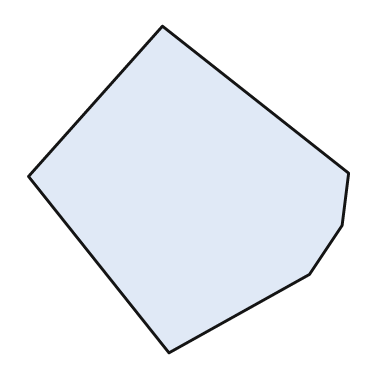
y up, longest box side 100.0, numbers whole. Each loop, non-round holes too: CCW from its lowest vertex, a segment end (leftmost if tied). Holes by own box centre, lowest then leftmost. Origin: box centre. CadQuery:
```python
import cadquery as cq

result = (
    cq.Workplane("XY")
    .moveTo(-6.0, -50.0)
    .lineTo(37.0, -26.0)
    .lineTo(47.0, -11.0)
    .lineTo(49.0, 5.0)
    .lineTo(-8.0, 50.0)
    .lineTo(-49.0, 4.0)
    .close()
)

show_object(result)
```